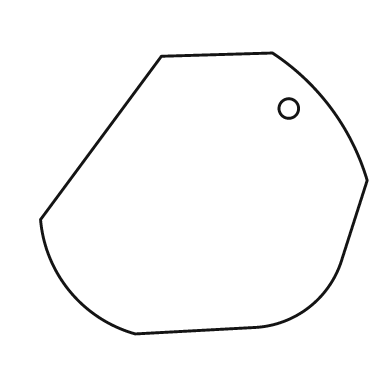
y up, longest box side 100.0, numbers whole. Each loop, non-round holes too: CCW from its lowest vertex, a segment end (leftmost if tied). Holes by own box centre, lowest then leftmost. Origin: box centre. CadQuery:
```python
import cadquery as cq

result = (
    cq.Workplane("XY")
    .moveTo(-21.0, -43.0)
    .lineTo(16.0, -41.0)
    .threePointArc((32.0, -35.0), (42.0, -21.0))
    .lineTo(50.0, 4.0)
    .threePointArc((39.0, 26.0), (21.0, 43.0))
    .lineTo(-13.0, 42.0)
    .lineTo(-50.0, -8.0)
    .threePointArc((-41.0, -30.0), (-21.0, -43.0))
    .close()
    .moveTo(26.0, 26.0)
    .circle(3.0)
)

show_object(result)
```